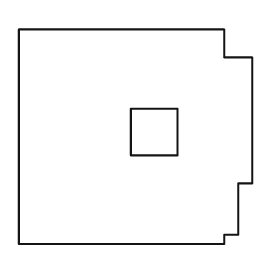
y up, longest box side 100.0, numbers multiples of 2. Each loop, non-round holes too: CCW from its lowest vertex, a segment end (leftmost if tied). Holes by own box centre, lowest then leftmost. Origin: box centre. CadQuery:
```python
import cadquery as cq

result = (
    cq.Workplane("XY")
    .moveTo(-50.0, -46.0)
    .lineTo(38.0, -46.0)
    .lineTo(38.0, -42.0)
    .lineTo(44.0, -42.0)
    .lineTo(44.0, -20.0)
    .lineTo(50.0, -20.0)
    .lineTo(50.0, 34.0)
    .lineTo(38.0, 34.0)
    .lineTo(38.0, 46.0)
    .lineTo(-50.0, 46.0)
    .close()
    .moveTo(-2.0, -8.0)
    .lineTo(18.0, -8.0)
    .lineTo(18.0, 12.0)
    .lineTo(-2.0, 12.0)
    .close()
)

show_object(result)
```